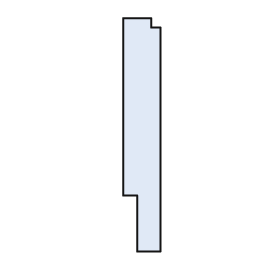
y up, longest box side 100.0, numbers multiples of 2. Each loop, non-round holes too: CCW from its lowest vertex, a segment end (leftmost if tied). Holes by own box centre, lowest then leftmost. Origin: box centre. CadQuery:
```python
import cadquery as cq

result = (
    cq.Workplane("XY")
    .moveTo(-2.0, -50.0)
    .lineTo(8.0, -50.0)
    .lineTo(8.0, 46.0)
    .lineTo(4.0, 46.0)
    .lineTo(4.0, 50.0)
    .lineTo(-8.0, 50.0)
    .lineTo(-8.0, -26.0)
    .lineTo(-2.0, -26.0)
    .close()
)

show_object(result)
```